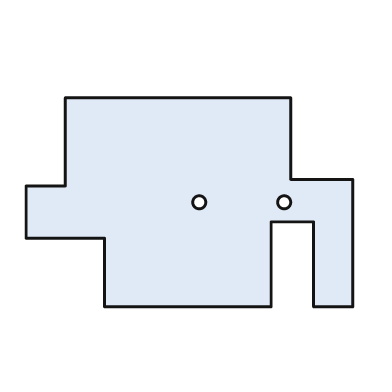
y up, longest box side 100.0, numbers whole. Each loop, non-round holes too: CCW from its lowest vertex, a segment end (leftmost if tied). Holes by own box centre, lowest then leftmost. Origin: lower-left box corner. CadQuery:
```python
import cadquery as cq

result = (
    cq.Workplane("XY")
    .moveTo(24.0, 0.0)
    .lineTo(75.0, 0.0)
    .lineTo(75.0, 26.0)
    .lineTo(88.0, 26.0)
    .lineTo(88.0, 0.0)
    .lineTo(100.0, 0.0)
    .lineTo(100.0, 39.0)
    .lineTo(81.0, 39.0)
    .lineTo(81.0, 64.0)
    .lineTo(12.0, 64.0)
    .lineTo(12.0, 37.0)
    .lineTo(0.0, 37.0)
    .lineTo(0.0, 21.0)
    .lineTo(24.0, 21.0)
    .close()
    .moveTo(53.0, 32.0)
    .circle(2.0)
    .moveTo(79.0, 32.0)
    .circle(2.0)
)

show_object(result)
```